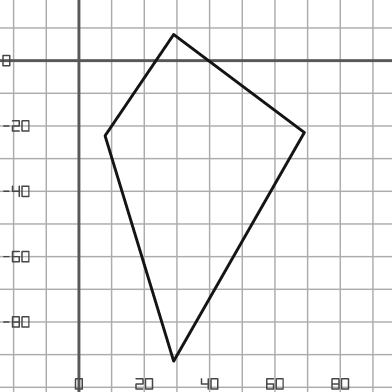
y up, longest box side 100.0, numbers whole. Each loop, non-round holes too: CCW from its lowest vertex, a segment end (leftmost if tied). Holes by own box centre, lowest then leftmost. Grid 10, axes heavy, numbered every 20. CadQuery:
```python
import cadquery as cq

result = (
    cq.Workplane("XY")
    .moveTo(29.0, -92.0)
    .lineTo(69.0, -22.0)
    .lineTo(29.0, 8.0)
    .lineTo(8.0, -23.0)
    .close()
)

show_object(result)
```